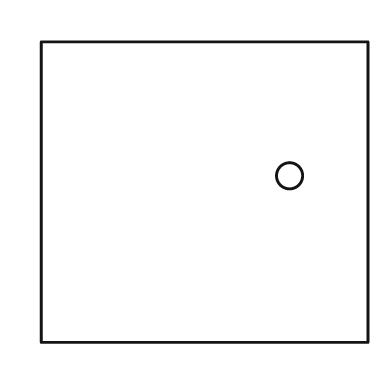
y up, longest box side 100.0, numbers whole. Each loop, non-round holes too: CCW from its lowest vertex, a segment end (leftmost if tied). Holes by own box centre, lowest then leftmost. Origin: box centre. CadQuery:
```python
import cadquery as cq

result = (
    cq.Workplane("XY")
    .moveTo(-50.0, -46.0)
    .lineTo(50.0, -46.0)
    .lineTo(50.0, 46.0)
    .lineTo(-50.0, 46.0)
    .close()
    .moveTo(26.0, 5.0)
    .circle(4.0)
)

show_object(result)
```